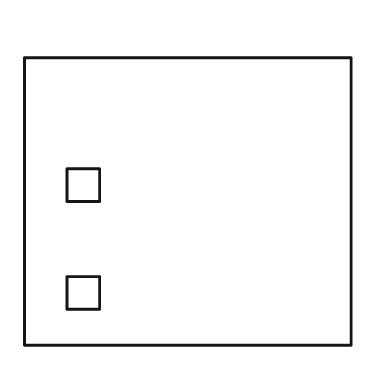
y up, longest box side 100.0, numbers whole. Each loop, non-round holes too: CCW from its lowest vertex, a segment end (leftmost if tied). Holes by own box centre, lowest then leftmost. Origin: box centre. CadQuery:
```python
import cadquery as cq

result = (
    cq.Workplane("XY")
    .moveTo(-50.0, -44.0)
    .lineTo(50.0, -44.0)
    .lineTo(50.0, 44.0)
    .lineTo(-50.0, 44.0)
    .close()
    .moveTo(-37.0, -33.0)
    .lineTo(-27.0, -33.0)
    .lineTo(-27.0, -23.0)
    .lineTo(-37.0, -23.0)
    .close()
    .moveTo(-37.0, 0.0)
    .lineTo(-27.0, 0.0)
    .lineTo(-27.0, 10.0)
    .lineTo(-37.0, 10.0)
    .close()
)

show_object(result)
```